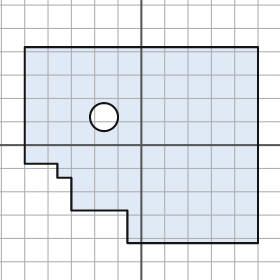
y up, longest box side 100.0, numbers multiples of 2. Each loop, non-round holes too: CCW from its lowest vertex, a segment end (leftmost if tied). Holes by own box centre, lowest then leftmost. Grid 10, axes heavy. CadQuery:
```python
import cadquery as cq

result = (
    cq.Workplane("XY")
    .moveTo(-6.0, -42.0)
    .lineTo(50.0, -42.0)
    .lineTo(50.0, 42.0)
    .lineTo(-50.0, 42.0)
    .lineTo(-50.0, -8.0)
    .lineTo(-36.0, -8.0)
    .lineTo(-36.0, -14.0)
    .lineTo(-30.0, -14.0)
    .lineTo(-30.0, -28.0)
    .lineTo(-6.0, -28.0)
    .close()
    .moveTo(-16.0, 12.0)
    .circle(6.0)
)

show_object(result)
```